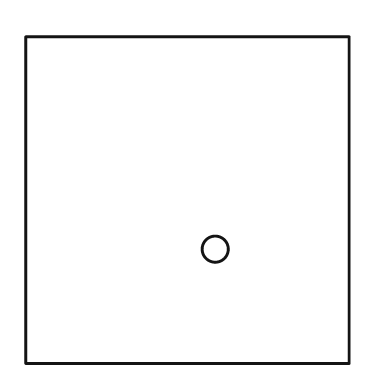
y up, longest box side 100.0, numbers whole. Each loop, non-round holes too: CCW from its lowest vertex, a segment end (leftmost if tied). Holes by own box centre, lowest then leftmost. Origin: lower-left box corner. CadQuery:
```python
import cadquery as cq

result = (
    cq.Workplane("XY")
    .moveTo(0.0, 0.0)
    .lineTo(99.0, 0.0)
    .lineTo(99.0, 100.0)
    .lineTo(0.0, 100.0)
    .close()
    .moveTo(58.0, 35.0)
    .circle(4.0)
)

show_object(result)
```